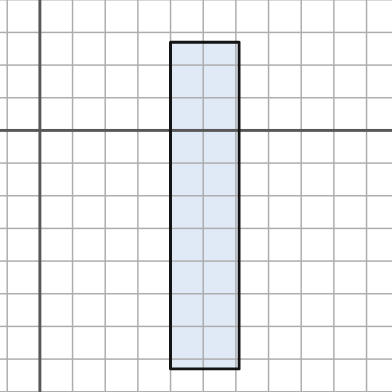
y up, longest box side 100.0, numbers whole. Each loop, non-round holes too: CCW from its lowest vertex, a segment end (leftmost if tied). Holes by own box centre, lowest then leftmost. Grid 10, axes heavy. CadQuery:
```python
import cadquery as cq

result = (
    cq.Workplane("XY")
    .moveTo(40.0, -73.0)
    .lineTo(61.0, -73.0)
    .lineTo(61.0, 27.0)
    .lineTo(40.0, 27.0)
    .close()
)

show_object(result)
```